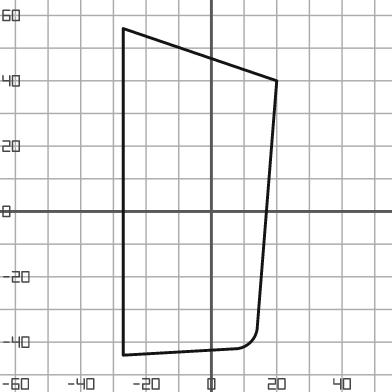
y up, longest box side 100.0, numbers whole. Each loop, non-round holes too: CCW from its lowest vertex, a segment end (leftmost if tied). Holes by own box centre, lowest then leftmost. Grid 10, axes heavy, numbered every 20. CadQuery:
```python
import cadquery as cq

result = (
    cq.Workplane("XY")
    .moveTo(-27.0, -44.0)
    .lineTo(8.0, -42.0)
    .threePointArc((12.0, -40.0), (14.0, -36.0))
    .lineTo(20.0, 40.0)
    .lineTo(-27.0, 56.0)
    .close()
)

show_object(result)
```